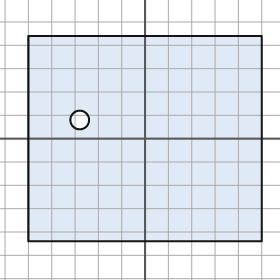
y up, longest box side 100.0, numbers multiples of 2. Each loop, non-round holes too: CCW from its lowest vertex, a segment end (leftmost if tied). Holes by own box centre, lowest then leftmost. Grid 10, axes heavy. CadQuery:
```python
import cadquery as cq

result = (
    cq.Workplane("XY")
    .moveTo(-50.0, -44.0)
    .lineTo(50.0, -44.0)
    .lineTo(50.0, 44.0)
    .lineTo(-50.0, 44.0)
    .close()
    .moveTo(-28.0, 8.0)
    .circle(4.0)
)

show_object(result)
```